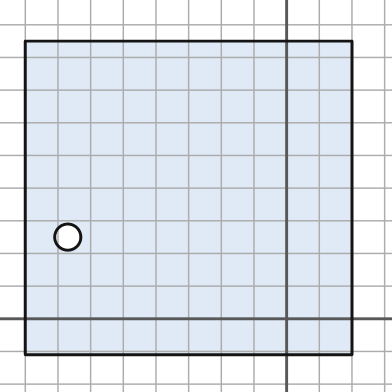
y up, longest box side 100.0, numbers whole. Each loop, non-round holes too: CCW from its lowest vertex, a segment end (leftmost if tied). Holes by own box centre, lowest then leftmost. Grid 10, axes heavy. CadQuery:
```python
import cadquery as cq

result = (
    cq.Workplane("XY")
    .moveTo(-80.0, -11.0)
    .lineTo(20.0, -11.0)
    .lineTo(20.0, 85.0)
    .lineTo(-80.0, 85.0)
    .close()
    .moveTo(-67.0, 25.0)
    .circle(4.0)
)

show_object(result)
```